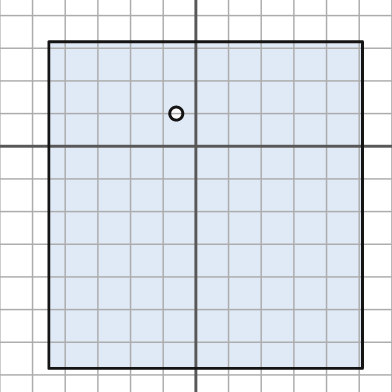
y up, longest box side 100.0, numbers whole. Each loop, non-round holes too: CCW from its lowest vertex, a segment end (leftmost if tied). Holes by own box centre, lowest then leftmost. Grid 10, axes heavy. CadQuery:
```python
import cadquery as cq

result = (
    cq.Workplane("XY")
    .moveTo(-45.0, -68.0)
    .lineTo(51.0, -68.0)
    .lineTo(51.0, 32.0)
    .lineTo(-45.0, 32.0)
    .close()
    .moveTo(-6.0, 10.0)
    .circle(2.0)
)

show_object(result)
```